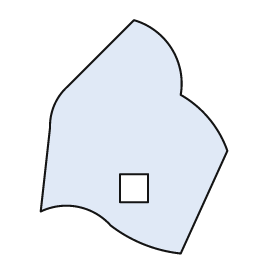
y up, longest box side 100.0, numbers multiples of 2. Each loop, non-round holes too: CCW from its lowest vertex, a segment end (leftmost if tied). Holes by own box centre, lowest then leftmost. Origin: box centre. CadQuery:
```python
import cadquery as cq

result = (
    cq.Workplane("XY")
    .moveTo(20.0, -50.0)
    .lineTo(40.0, -6.0)
    .threePointArc((32.0, 8.0), (20.0, 18.0))
    .threePointArc((16.0, 38.0), (0.0, 50.0))
    .lineTo(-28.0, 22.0)
    .threePointArc((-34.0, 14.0), (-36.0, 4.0))
    .lineTo(-40.0, -32.0)
    .threePointArc((-24.0, -30.0), (-10.0, -38.0))
    .threePointArc((4.0, -46.0), (20.0, -50.0))
    .close()
    .moveTo(-6.0, -28.0)
    .lineTo(6.0, -28.0)
    .lineTo(6.0, -16.0)
    .lineTo(-6.0, -16.0)
    .close()
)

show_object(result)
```